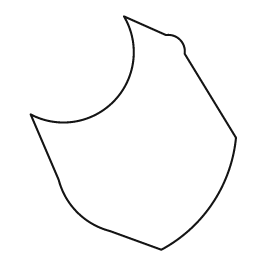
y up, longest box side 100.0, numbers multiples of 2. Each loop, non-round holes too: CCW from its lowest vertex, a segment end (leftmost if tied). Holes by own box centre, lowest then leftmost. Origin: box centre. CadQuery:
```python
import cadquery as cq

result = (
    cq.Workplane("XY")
    .moveTo(12.0, -50.0)
    .threePointArc((34.0, -30.0), (44.0, -2.0))
    .lineTo(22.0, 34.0)
    .threePointArc((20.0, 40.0), (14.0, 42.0))
    .lineTo(-4.0, 50.0)
    .threePointArc((-8.0, 14.0), (-44.0, 8.0))
    .lineTo(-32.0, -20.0)
    .threePointArc((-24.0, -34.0), (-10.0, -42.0))
    .close()
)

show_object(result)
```